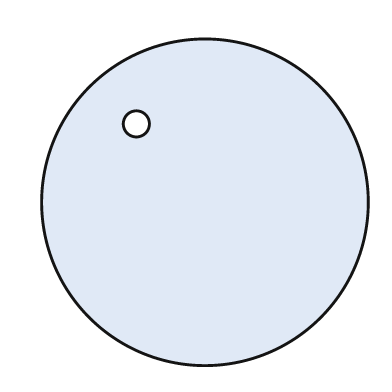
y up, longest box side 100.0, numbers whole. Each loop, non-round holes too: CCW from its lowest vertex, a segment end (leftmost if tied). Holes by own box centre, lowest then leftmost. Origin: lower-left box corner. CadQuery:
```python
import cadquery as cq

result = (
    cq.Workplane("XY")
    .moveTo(50.0, 50.0)
    .circle(50.0)
    .moveTo(29.0, 74.0)
    .circle(4.0)
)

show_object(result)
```